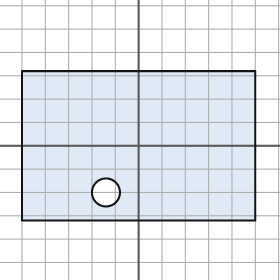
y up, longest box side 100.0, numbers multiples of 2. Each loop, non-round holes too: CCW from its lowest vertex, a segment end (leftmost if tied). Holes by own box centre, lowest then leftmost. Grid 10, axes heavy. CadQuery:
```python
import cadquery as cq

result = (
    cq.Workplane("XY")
    .moveTo(-50.0, -32.0)
    .lineTo(50.0, -32.0)
    .lineTo(50.0, 32.0)
    .lineTo(-50.0, 32.0)
    .close()
    .moveTo(-14.0, -20.0)
    .circle(6.0)
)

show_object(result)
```